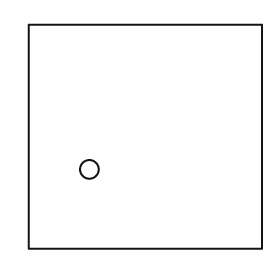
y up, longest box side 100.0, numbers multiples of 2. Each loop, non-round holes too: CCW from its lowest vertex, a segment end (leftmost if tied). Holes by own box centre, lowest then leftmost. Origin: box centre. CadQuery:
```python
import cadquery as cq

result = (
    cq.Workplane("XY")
    .moveTo(-50.0, -48.0)
    .lineTo(50.0, -48.0)
    .lineTo(50.0, 48.0)
    .lineTo(-50.0, 48.0)
    .close()
    .moveTo(-24.0, -14.0)
    .circle(4.0)
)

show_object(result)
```